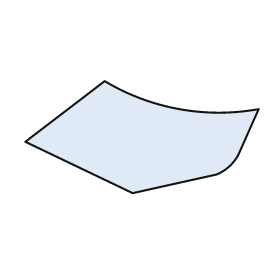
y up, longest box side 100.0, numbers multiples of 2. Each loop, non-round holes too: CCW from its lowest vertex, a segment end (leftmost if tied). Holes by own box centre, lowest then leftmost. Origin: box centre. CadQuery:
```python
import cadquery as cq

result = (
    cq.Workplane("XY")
    .moveTo(-4.0, -24.0)
    .lineTo(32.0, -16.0)
    .threePointArc((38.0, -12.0), (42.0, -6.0))
    .lineTo(50.0, 12.0)
    .threePointArc((16.0, 12.0), (-16.0, 24.0))
    .lineTo(-50.0, -2.0)
    .close()
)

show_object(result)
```